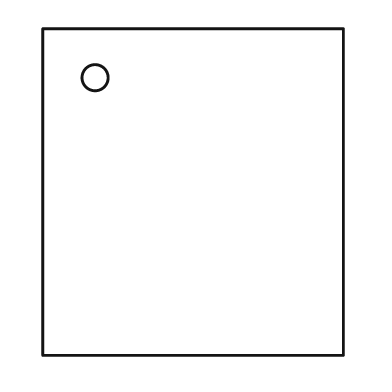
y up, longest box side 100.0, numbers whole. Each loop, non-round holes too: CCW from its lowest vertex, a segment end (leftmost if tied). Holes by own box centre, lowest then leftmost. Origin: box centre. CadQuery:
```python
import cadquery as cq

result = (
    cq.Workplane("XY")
    .moveTo(-46.0, -50.0)
    .lineTo(46.0, -50.0)
    .lineTo(46.0, 50.0)
    .lineTo(-46.0, 50.0)
    .close()
    .moveTo(-30.0, 35.0)
    .circle(4.0)
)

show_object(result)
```